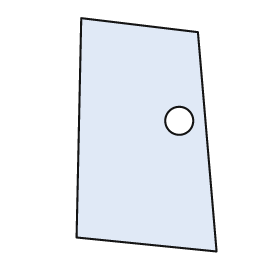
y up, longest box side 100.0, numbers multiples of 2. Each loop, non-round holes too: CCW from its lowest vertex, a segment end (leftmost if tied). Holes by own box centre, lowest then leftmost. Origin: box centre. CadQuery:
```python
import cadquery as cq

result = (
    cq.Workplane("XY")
    .moveTo(30.0, -50.0)
    .lineTo(22.0, 44.0)
    .lineTo(-28.0, 50.0)
    .lineTo(-30.0, -44.0)
    .close()
    .moveTo(14.0, 6.0)
    .circle(6.0)
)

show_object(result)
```